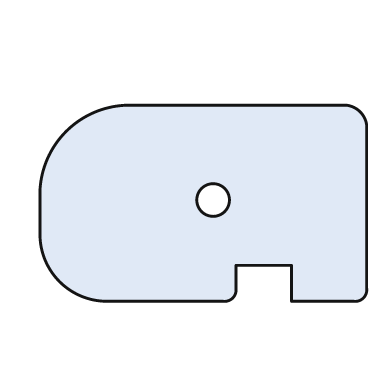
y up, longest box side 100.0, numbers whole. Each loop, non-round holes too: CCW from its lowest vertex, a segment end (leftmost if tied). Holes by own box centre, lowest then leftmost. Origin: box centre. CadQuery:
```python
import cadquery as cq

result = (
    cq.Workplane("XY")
    .moveTo(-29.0, -30.0)
    .lineTo(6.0, -30.0)
    .threePointArc((9.0, -29.0), (10.0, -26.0))
    .lineTo(10.0, -19.0)
    .lineTo(27.0, -19.0)
    .lineTo(27.0, -30.0)
    .lineTo(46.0, -30.0)
    .threePointArc((49.0, -29.0), (50.0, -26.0))
    .lineTo(50.0, 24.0)
    .threePointArc((48.0, 28.0), (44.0, 30.0))
    .lineTo(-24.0, 30.0)
    .threePointArc((-42.0, 22.0), (-50.0, 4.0))
    .lineTo(-50.0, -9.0)
    .threePointArc((-44.0, -24.0), (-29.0, -30.0))
    .close()
    .moveTo(3.0, 1.0)
    .circle(5.0)
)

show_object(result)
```